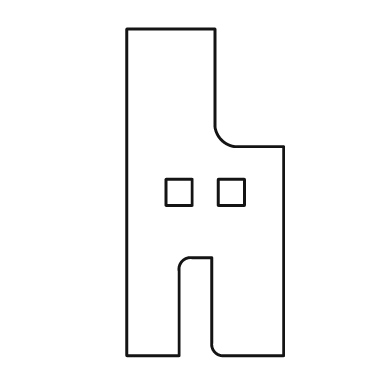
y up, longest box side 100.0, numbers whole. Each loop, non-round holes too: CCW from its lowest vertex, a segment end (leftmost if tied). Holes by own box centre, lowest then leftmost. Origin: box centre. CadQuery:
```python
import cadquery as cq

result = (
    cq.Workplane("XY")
    .moveTo(-24.0, -50.0)
    .lineTo(-8.0, -50.0)
    .lineTo(-8.0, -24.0)
    .threePointArc((-7.0, -21.0), (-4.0, -20.0))
    .lineTo(2.0, -20.0)
    .lineTo(2.0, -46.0)
    .threePointArc((3.0, -49.0), (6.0, -50.0))
    .lineTo(24.0, -50.0)
    .lineTo(24.0, 14.0)
    .lineTo(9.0, 14.0)
    .threePointArc((5.0, 16.0), (3.0, 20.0))
    .lineTo(3.0, 50.0)
    .lineTo(-24.0, 50.0)
    .close()
    .moveTo(-12.0, -4.0)
    .lineTo(-4.0, -4.0)
    .lineTo(-4.0, 4.0)
    .lineTo(-12.0, 4.0)
    .close()
    .moveTo(4.0, -4.0)
    .lineTo(12.0, -4.0)
    .lineTo(12.0, 4.0)
    .lineTo(4.0, 4.0)
    .close()
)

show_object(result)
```